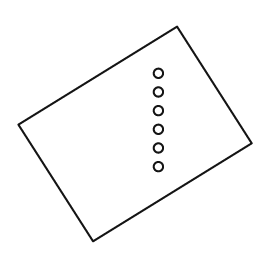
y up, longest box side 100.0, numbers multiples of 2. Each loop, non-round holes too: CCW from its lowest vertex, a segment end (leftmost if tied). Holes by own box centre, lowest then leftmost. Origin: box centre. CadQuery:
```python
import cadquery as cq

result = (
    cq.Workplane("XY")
    .moveTo(-18.0, -46.0)
    .lineTo(50.0, -4.0)
    .lineTo(18.0, 46.0)
    .lineTo(-50.0, 4.0)
    .close()
    .moveTo(10.0, -14.0)
    .circle(2.0)
    .moveTo(10.0, -6.0)
    .circle(2.0)
    .moveTo(10.0, 2.0)
    .circle(2.0)
    .moveTo(10.0, 10.0)
    .circle(2.0)
    .moveTo(10.0, 18.0)
    .circle(2.0)
    .moveTo(10.0, 26.0)
    .circle(2.0)
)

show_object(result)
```